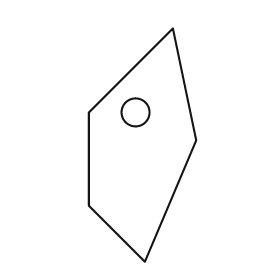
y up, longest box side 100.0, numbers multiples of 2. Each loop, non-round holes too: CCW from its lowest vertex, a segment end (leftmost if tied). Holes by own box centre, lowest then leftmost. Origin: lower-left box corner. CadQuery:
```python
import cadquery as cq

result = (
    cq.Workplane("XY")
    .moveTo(24.0, 0.0)
    .lineTo(46.0, 52.0)
    .lineTo(36.0, 100.0)
    .lineTo(0.0, 64.0)
    .lineTo(0.0, 24.0)
    .close()
    .moveTo(20.0, 64.0)
    .circle(6.0)
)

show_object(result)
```